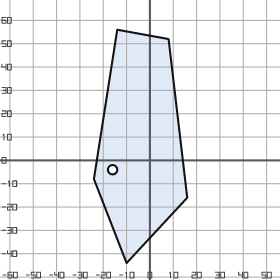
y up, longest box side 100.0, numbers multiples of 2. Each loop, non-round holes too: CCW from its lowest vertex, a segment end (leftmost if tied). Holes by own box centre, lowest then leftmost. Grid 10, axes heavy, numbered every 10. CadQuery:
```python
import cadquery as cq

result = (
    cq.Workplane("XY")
    .moveTo(-10.0, -44.0)
    .lineTo(16.0, -16.0)
    .lineTo(8.0, 52.0)
    .lineTo(-14.0, 56.0)
    .lineTo(-24.0, -8.0)
    .close()
    .moveTo(-16.0, -4.0)
    .circle(2.0)
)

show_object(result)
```